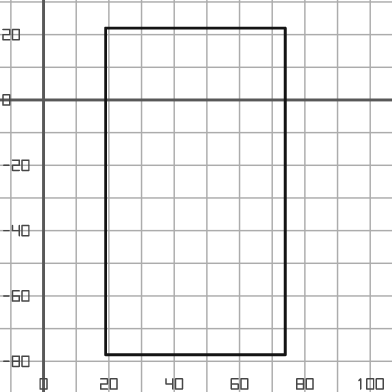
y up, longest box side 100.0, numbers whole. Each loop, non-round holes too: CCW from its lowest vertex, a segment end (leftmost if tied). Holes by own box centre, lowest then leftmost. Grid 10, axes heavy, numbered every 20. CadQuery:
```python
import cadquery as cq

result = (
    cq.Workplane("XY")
    .moveTo(19.0, -78.0)
    .lineTo(74.0, -78.0)
    .lineTo(74.0, 22.0)
    .lineTo(19.0, 22.0)
    .close()
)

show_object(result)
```